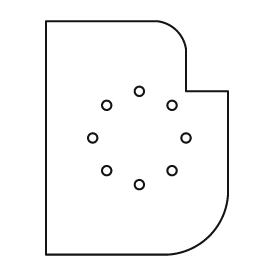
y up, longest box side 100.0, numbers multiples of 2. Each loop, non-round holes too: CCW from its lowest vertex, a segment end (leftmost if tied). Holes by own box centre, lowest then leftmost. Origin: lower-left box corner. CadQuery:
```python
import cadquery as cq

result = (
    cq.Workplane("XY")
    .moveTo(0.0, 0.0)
    .lineTo(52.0, 0.0)
    .threePointArc((70.0, 8.0), (78.0, 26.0))
    .lineTo(78.0, 70.0)
    .lineTo(60.0, 70.0)
    .lineTo(60.0, 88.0)
    .threePointArc((56.0, 96.0), (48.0, 100.0))
    .lineTo(0.0, 100.0)
    .close()
    .moveTo(40.0, 30.0)
    .circle(2.0)
    .moveTo(26.0, 36.0)
    .circle(2.0)
    .moveTo(54.0, 36.0)
    .circle(2.0)
    .moveTo(20.0, 50.0)
    .circle(2.0)
    .moveTo(60.0, 50.0)
    .circle(2.0)
    .moveTo(26.0, 64.0)
    .circle(2.0)
    .moveTo(54.0, 64.0)
    .circle(2.0)
    .moveTo(40.0, 70.0)
    .circle(2.0)
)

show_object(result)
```